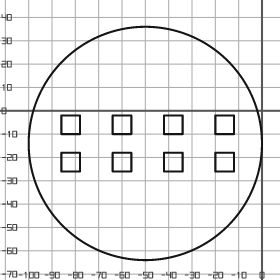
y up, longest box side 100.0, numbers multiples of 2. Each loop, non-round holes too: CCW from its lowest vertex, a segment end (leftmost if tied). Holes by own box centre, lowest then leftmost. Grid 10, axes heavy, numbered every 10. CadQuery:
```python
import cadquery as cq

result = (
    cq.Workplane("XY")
    .moveTo(-50.0, -14.0)
    .circle(50.0)
    .moveTo(-86.0, -26.0)
    .lineTo(-78.0, -26.0)
    .lineTo(-78.0, -18.0)
    .lineTo(-86.0, -18.0)
    .close()
    .moveTo(-64.0, -26.0)
    .lineTo(-56.0, -26.0)
    .lineTo(-56.0, -18.0)
    .lineTo(-64.0, -18.0)
    .close()
    .moveTo(-42.0, -26.0)
    .lineTo(-34.0, -26.0)
    .lineTo(-34.0, -18.0)
    .lineTo(-42.0, -18.0)
    .close()
    .moveTo(-20.0, -26.0)
    .lineTo(-12.0, -26.0)
    .lineTo(-12.0, -18.0)
    .lineTo(-20.0, -18.0)
    .close()
    .moveTo(-86.0, -10.0)
    .lineTo(-78.0, -10.0)
    .lineTo(-78.0, -2.0)
    .lineTo(-86.0, -2.0)
    .close()
    .moveTo(-64.0, -10.0)
    .lineTo(-56.0, -10.0)
    .lineTo(-56.0, -2.0)
    .lineTo(-64.0, -2.0)
    .close()
    .moveTo(-42.0, -10.0)
    .lineTo(-34.0, -10.0)
    .lineTo(-34.0, -2.0)
    .lineTo(-42.0, -2.0)
    .close()
    .moveTo(-20.0, -10.0)
    .lineTo(-12.0, -10.0)
    .lineTo(-12.0, -2.0)
    .lineTo(-20.0, -2.0)
    .close()
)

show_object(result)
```